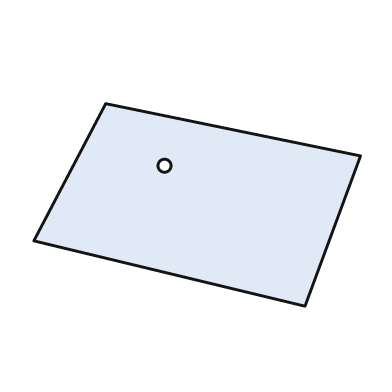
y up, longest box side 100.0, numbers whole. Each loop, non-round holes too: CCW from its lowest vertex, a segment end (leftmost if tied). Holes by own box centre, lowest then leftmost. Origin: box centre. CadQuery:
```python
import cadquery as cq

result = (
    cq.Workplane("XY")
    .moveTo(33.0, -31.0)
    .lineTo(50.0, 15.0)
    .lineTo(-28.0, 31.0)
    .lineTo(-50.0, -11.0)
    .close()
    .moveTo(-10.0, 12.0)
    .circle(2.0)
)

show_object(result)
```